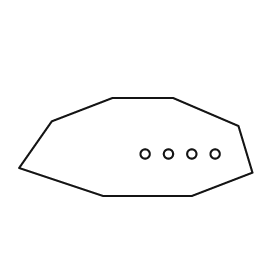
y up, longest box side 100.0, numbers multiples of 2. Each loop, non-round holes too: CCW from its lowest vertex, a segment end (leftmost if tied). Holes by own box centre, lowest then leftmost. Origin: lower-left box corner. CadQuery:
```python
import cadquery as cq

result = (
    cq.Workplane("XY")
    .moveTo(36.0, 0.0)
    .lineTo(74.0, 0.0)
    .lineTo(100.0, 10.0)
    .lineTo(94.0, 30.0)
    .lineTo(66.0, 42.0)
    .lineTo(40.0, 42.0)
    .lineTo(14.0, 32.0)
    .lineTo(0.0, 12.0)
    .close()
    .moveTo(54.0, 18.0)
    .circle(2.0)
    .moveTo(64.0, 18.0)
    .circle(2.0)
    .moveTo(74.0, 18.0)
    .circle(2.0)
    .moveTo(84.0, 18.0)
    .circle(2.0)
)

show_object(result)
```